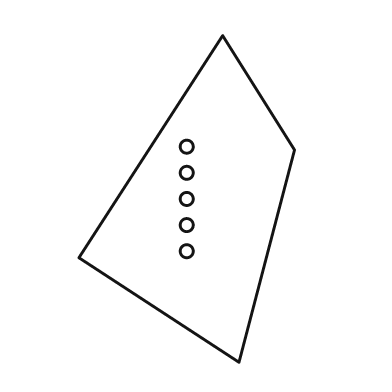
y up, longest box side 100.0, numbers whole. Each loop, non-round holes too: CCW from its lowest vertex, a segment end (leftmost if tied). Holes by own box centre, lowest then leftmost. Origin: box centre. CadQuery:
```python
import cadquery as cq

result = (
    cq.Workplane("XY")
    .moveTo(16.0, -50.0)
    .lineTo(33.0, 15.0)
    .lineTo(11.0, 50.0)
    .lineTo(-33.0, -18.0)
    .close()
    .moveTo(0.0, -16.0)
    .circle(2.0)
    .moveTo(0.0, -8.0)
    .circle(2.0)
    .moveTo(0.0, 0.0)
    .circle(2.0)
    .moveTo(0.0, 8.0)
    .circle(2.0)
    .moveTo(0.0, 16.0)
    .circle(2.0)
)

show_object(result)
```